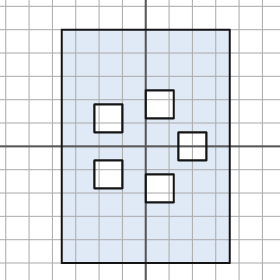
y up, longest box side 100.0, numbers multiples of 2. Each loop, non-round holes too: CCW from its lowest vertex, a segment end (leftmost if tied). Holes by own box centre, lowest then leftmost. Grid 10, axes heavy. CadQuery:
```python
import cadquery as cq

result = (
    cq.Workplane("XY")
    .moveTo(-36.0, -50.0)
    .lineTo(36.0, -50.0)
    .lineTo(36.0, 50.0)
    .lineTo(-36.0, 50.0)
    .close()
    .moveTo(0.0, -24.0)
    .lineTo(12.0, -24.0)
    .lineTo(12.0, -12.0)
    .lineTo(0.0, -12.0)
    .close()
    .moveTo(-22.0, -18.0)
    .lineTo(-10.0, -18.0)
    .lineTo(-10.0, -6.0)
    .lineTo(-22.0, -6.0)
    .close()
    .moveTo(14.0, -6.0)
    .lineTo(26.0, -6.0)
    .lineTo(26.0, 6.0)
    .lineTo(14.0, 6.0)
    .close()
    .moveTo(-22.0, 6.0)
    .lineTo(-10.0, 6.0)
    .lineTo(-10.0, 18.0)
    .lineTo(-22.0, 18.0)
    .close()
    .moveTo(0.0, 12.0)
    .lineTo(12.0, 12.0)
    .lineTo(12.0, 24.0)
    .lineTo(0.0, 24.0)
    .close()
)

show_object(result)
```